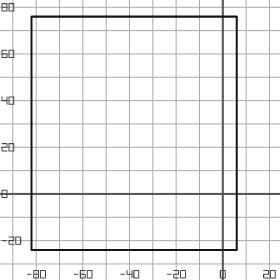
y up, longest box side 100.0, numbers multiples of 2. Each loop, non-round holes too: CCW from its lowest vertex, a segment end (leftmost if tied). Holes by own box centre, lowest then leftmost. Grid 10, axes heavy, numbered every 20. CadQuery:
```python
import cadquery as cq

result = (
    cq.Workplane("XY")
    .moveTo(-82.0, -24.0)
    .lineTo(6.0, -24.0)
    .lineTo(6.0, 76.0)
    .lineTo(-82.0, 76.0)
    .close()
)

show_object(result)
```